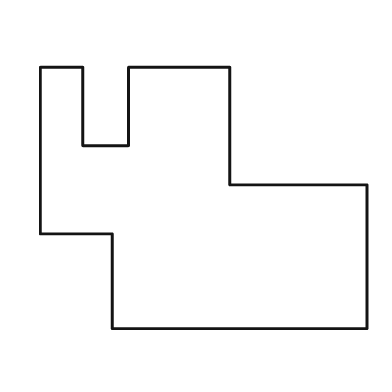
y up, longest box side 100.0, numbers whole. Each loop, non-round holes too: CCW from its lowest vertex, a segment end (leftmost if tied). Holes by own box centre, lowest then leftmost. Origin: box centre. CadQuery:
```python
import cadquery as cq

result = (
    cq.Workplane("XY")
    .moveTo(-28.0, -40.0)
    .lineTo(50.0, -40.0)
    .lineTo(50.0, 4.0)
    .lineTo(8.0, 4.0)
    .lineTo(8.0, 40.0)
    .lineTo(-23.0, 40.0)
    .lineTo(-23.0, 16.0)
    .lineTo(-37.0, 16.0)
    .lineTo(-37.0, 40.0)
    .lineTo(-50.0, 40.0)
    .lineTo(-50.0, -11.0)
    .lineTo(-28.0, -11.0)
    .close()
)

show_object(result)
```